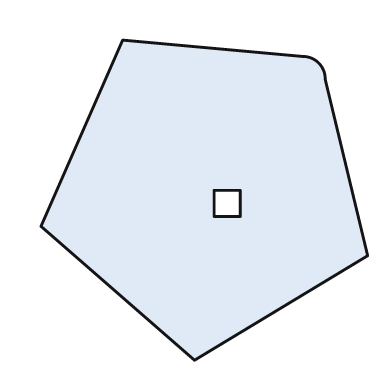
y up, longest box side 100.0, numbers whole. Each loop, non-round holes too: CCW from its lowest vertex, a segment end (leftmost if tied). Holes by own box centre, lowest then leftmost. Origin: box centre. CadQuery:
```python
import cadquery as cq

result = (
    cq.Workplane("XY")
    .moveTo(-3.0, -49.0)
    .lineTo(50.0, -17.0)
    .lineTo(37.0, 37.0)
    .threePointArc((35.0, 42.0), (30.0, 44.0))
    .lineTo(-25.0, 49.0)
    .lineTo(-50.0, -8.0)
    .close()
    .moveTo(3.0, -5.0)
    .lineTo(11.0, -5.0)
    .lineTo(11.0, 3.0)
    .lineTo(3.0, 3.0)
    .close()
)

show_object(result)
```